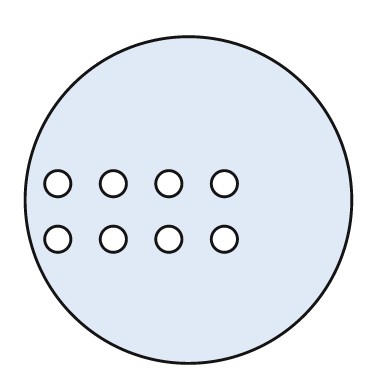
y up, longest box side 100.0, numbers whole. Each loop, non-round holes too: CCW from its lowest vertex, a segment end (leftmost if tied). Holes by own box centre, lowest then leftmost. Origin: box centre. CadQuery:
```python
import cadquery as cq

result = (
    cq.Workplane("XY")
    .moveTo(0.0, 0.0)
    .circle(50.0)
    .moveTo(-40.0, -12.0)
    .circle(4.0)
    .moveTo(-23.0, -12.0)
    .circle(4.0)
    .moveTo(-6.0, -12.0)
    .circle(4.0)
    .moveTo(11.0, -12.0)
    .circle(4.0)
    .moveTo(-40.0, 5.0)
    .circle(4.0)
    .moveTo(-23.0, 5.0)
    .circle(4.0)
    .moveTo(-6.0, 5.0)
    .circle(4.0)
    .moveTo(11.0, 5.0)
    .circle(4.0)
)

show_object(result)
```